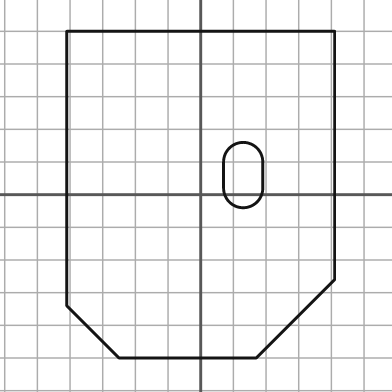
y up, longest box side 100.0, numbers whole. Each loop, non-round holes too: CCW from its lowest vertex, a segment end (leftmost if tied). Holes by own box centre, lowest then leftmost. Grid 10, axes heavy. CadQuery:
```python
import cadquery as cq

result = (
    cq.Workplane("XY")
    .moveTo(-25.0, -50.0)
    .lineTo(17.0, -50.0)
    .lineTo(41.0, -26.0)
    .lineTo(41.0, 50.0)
    .lineTo(-41.0, 50.0)
    .lineTo(-41.0, -34.0)
    .close()
    .moveTo(7.0, 2.0)
    .threePointArc((13.0, -4.0), (19.0, 2.0))
    .lineTo(19.0, 10.0)
    .threePointArc((13.0, 16.0), (7.0, 10.0))
    .close()
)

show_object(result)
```